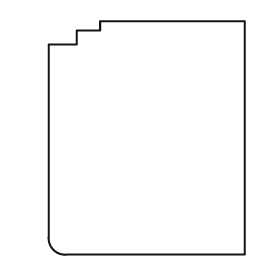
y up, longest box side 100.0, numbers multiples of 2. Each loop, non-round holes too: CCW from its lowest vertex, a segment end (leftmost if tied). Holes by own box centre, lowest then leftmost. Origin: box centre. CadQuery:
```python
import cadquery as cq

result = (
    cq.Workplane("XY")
    .moveTo(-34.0, -50.0)
    .lineTo(42.0, -50.0)
    .lineTo(42.0, 50.0)
    .lineTo(-20.0, 50.0)
    .lineTo(-20.0, 46.0)
    .lineTo(-30.0, 46.0)
    .lineTo(-30.0, 40.0)
    .lineTo(-42.0, 40.0)
    .lineTo(-42.0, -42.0)
    .threePointArc((-40.0, -48.0), (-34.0, -50.0))
    .close()
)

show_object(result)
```